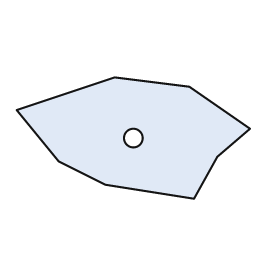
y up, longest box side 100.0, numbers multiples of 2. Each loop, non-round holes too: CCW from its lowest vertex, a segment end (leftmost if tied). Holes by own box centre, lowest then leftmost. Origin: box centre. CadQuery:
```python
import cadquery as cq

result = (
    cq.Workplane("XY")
    .moveTo(26.0, -26.0)
    .lineTo(36.0, -8.0)
    .lineTo(50.0, 4.0)
    .lineTo(24.0, 22.0)
    .lineTo(-8.0, 26.0)
    .lineTo(-50.0, 12.0)
    .lineTo(-32.0, -10.0)
    .lineTo(-12.0, -20.0)
    .close()
    .moveTo(0.0, 0.0)
    .circle(4.0)
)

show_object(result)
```